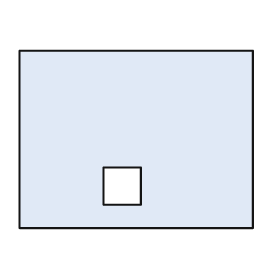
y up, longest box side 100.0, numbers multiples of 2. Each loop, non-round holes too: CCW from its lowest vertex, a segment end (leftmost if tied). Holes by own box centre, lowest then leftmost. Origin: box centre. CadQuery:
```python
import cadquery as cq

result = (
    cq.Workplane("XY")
    .moveTo(-50.0, -38.0)
    .lineTo(50.0, -38.0)
    .lineTo(50.0, 38.0)
    .lineTo(-50.0, 38.0)
    .close()
    .moveTo(-14.0, -28.0)
    .lineTo(2.0, -28.0)
    .lineTo(2.0, -12.0)
    .lineTo(-14.0, -12.0)
    .close()
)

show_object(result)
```